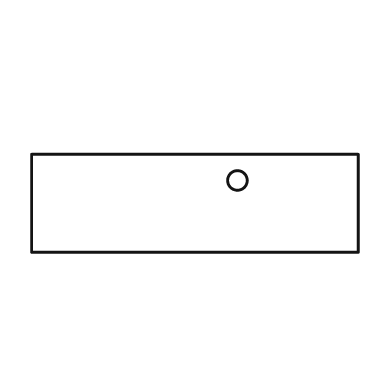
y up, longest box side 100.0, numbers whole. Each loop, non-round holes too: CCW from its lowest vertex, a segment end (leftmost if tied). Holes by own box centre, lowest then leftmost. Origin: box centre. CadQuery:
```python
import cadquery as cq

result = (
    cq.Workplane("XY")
    .moveTo(-50.0, -15.0)
    .lineTo(50.0, -15.0)
    .lineTo(50.0, 15.0)
    .lineTo(-50.0, 15.0)
    .close()
    .moveTo(13.0, 7.0)
    .circle(3.0)
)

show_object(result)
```